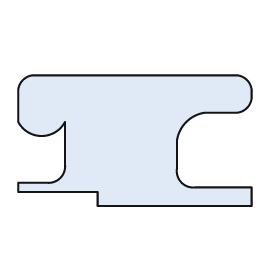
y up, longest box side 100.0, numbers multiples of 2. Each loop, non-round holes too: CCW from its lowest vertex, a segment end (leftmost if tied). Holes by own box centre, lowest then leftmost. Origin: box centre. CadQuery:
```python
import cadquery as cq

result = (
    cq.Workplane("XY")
    .moveTo(-16.0, -28.0)
    .lineTo(50.0, -28.0)
    .lineTo(50.0, -20.0)
    .lineTo(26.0, -20.0)
    .threePointArc((20.0, -18.0), (18.0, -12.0))
    .lineTo(18.0, 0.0)
    .threePointArc((22.0, 8.0), (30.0, 12.0))
    .lineTo(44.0, 12.0)
    .threePointArc((48.0, 14.0), (50.0, 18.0))
    .lineTo(50.0, 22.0)
    .threePointArc((48.0, 26.0), (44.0, 28.0))
    .lineTo(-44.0, 28.0)
    .threePointArc((-48.0, 26.0), (-50.0, 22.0))
    .lineTo(-50.0, 8.0)
    .threePointArc((-40.0, 2.0), (-30.0, 8.0))
    .lineTo(-30.0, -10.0)
    .threePointArc((-32.0, -16.0), (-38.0, -18.0))
    .lineTo(-50.0, -18.0)
    .lineTo(-50.0, -22.0)
    .lineTo(-16.0, -22.0)
    .close()
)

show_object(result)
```